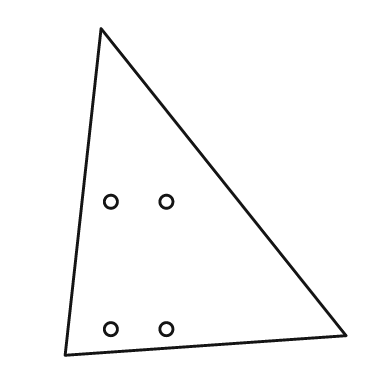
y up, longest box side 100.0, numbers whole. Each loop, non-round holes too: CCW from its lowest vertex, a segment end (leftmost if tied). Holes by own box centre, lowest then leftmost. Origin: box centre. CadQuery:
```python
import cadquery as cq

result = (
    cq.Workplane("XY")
    .moveTo(-43.0, -50.0)
    .lineTo(43.0, -44.0)
    .lineTo(-32.0, 50.0)
    .close()
    .moveTo(-29.0, -42.0)
    .circle(2.0)
    .moveTo(-12.0, -42.0)
    .circle(2.0)
    .moveTo(-29.0, -3.0)
    .circle(2.0)
    .moveTo(-12.0, -3.0)
    .circle(2.0)
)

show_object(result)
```